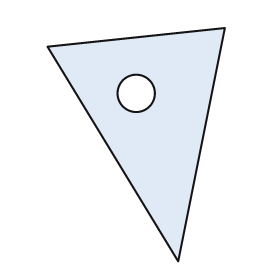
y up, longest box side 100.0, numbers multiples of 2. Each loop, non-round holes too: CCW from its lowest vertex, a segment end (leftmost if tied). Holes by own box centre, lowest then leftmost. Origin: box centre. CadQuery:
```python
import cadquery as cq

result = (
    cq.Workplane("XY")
    .moveTo(18.0, -50.0)
    .lineTo(38.0, 50.0)
    .lineTo(-38.0, 42.0)
    .close()
    .moveTo(0.0, 22.0)
    .circle(8.0)
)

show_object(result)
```